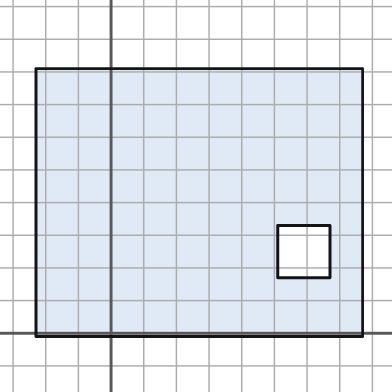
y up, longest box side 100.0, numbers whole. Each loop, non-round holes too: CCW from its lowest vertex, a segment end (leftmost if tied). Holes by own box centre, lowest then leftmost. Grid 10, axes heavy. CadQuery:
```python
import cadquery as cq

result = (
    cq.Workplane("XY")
    .moveTo(-23.0, -1.0)
    .lineTo(77.0, -1.0)
    .lineTo(77.0, 81.0)
    .lineTo(-23.0, 81.0)
    .close()
    .moveTo(51.0, 17.0)
    .lineTo(67.0, 17.0)
    .lineTo(67.0, 33.0)
    .lineTo(51.0, 33.0)
    .close()
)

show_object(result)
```